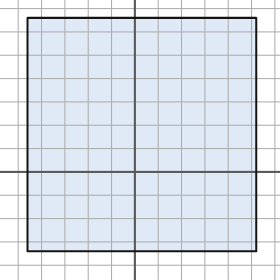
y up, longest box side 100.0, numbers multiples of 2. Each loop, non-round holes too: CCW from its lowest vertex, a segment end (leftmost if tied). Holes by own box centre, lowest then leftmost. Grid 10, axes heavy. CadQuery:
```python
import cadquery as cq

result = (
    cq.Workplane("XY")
    .moveTo(-46.0, -34.0)
    .lineTo(52.0, -34.0)
    .lineTo(52.0, 66.0)
    .lineTo(-46.0, 66.0)
    .close()
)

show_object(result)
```